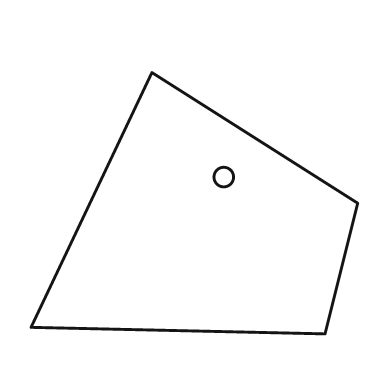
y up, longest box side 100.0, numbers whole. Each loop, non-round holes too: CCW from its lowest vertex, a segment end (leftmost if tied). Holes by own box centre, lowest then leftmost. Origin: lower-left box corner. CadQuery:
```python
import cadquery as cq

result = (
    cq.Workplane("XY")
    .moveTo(90.0, 0.0)
    .lineTo(100.0, 40.0)
    .lineTo(37.0, 80.0)
    .lineTo(0.0, 2.0)
    .close()
    .moveTo(59.0, 48.0)
    .circle(3.0)
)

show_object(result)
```